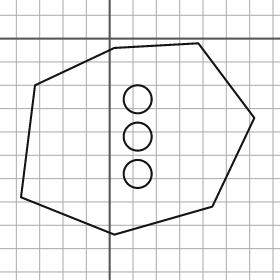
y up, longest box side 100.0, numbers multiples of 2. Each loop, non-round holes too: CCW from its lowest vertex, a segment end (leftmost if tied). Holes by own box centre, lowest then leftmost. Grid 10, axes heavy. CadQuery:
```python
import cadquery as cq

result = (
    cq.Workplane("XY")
    .moveTo(2.0, -84.0)
    .lineTo(44.0, -72.0)
    .lineTo(62.0, -34.0)
    .lineTo(38.0, -2.0)
    .lineTo(2.0, -4.0)
    .lineTo(-32.0, -20.0)
    .lineTo(-38.0, -68.0)
    .close()
    .moveTo(12.0, -58.0)
    .circle(6.0)
    .moveTo(12.0, -42.0)
    .circle(6.0)
    .moveTo(12.0, -26.0)
    .circle(6.0)
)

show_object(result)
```